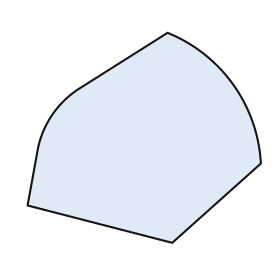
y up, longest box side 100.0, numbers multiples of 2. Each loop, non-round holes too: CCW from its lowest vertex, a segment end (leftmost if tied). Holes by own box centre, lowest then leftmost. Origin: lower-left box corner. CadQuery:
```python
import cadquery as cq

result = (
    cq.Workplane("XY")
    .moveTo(62.0, 0.0)
    .lineTo(100.0, 34.0)
    .threePointArc((88.0, 68.0), (60.0, 90.0))
    .lineTo(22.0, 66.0)
    .threePointArc((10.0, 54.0), (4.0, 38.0))
    .lineTo(0.0, 16.0)
    .close()
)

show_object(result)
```